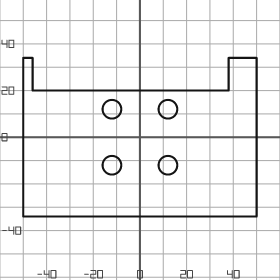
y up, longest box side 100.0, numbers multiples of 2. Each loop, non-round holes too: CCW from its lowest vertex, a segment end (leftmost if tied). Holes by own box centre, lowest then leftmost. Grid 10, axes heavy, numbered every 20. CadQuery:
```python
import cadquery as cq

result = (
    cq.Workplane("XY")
    .moveTo(-50.0, -34.0)
    .lineTo(50.0, -34.0)
    .lineTo(50.0, 34.0)
    .lineTo(38.0, 34.0)
    .lineTo(38.0, 20.0)
    .lineTo(-46.0, 20.0)
    .lineTo(-46.0, 34.0)
    .lineTo(-50.0, 34.0)
    .close()
    .moveTo(-12.0, -12.0)
    .circle(4.0)
    .moveTo(12.0, -12.0)
    .circle(4.0)
    .moveTo(-12.0, 12.0)
    .circle(4.0)
    .moveTo(12.0, 12.0)
    .circle(4.0)
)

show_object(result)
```